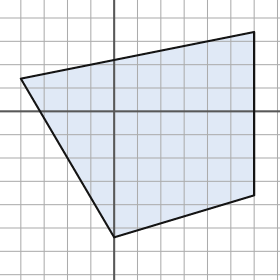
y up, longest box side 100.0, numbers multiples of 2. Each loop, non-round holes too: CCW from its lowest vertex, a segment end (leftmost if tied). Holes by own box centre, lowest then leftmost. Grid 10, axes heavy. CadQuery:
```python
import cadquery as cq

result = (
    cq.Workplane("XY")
    .moveTo(0.0, -54.0)
    .lineTo(60.0, -36.0)
    .lineTo(60.0, 34.0)
    .lineTo(-40.0, 14.0)
    .close()
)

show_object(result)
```